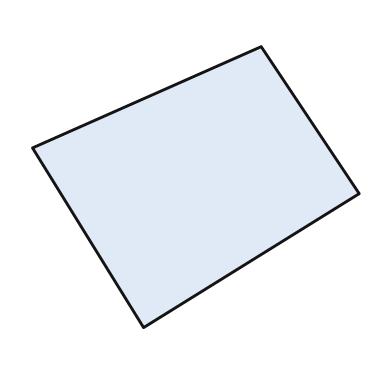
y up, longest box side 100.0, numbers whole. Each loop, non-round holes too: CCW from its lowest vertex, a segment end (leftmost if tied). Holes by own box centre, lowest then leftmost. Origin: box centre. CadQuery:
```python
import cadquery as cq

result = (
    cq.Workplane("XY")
    .moveTo(-16.0, -43.0)
    .lineTo(50.0, -2.0)
    .lineTo(20.0, 43.0)
    .lineTo(-50.0, 12.0)
    .close()
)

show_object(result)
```